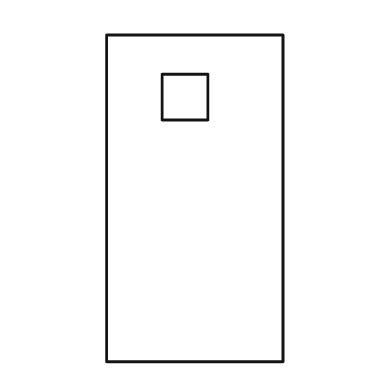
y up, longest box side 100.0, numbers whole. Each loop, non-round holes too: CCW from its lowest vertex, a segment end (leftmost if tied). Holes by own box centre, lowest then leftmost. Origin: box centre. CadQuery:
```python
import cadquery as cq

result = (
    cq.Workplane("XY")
    .moveTo(-27.0, -50.0)
    .lineTo(27.0, -50.0)
    .lineTo(27.0, 50.0)
    .lineTo(-27.0, 50.0)
    .close()
    .moveTo(-10.0, 24.0)
    .lineTo(4.0, 24.0)
    .lineTo(4.0, 38.0)
    .lineTo(-10.0, 38.0)
    .close()
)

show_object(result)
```